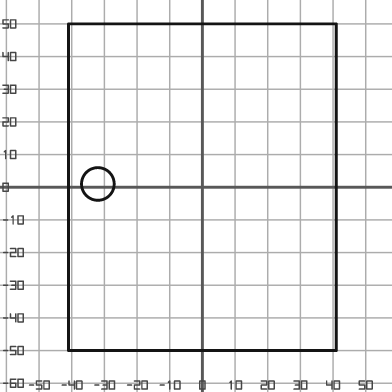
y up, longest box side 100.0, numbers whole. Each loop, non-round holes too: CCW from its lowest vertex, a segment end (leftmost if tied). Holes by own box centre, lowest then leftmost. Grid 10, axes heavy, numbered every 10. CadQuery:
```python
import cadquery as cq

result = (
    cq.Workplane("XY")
    .moveTo(-41.0, -50.0)
    .lineTo(41.0, -50.0)
    .lineTo(41.0, 50.0)
    .lineTo(-41.0, 50.0)
    .close()
    .moveTo(-32.0, 1.0)
    .circle(5.0)
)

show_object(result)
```